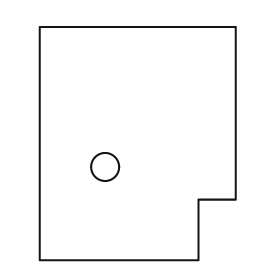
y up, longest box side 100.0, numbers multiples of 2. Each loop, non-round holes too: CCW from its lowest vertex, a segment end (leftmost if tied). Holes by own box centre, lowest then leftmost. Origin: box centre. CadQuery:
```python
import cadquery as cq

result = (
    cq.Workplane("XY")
    .moveTo(-42.0, -50.0)
    .lineTo(26.0, -50.0)
    .lineTo(26.0, -24.0)
    .lineTo(42.0, -24.0)
    .lineTo(42.0, 50.0)
    .lineTo(-42.0, 50.0)
    .close()
    .moveTo(-14.0, -10.0)
    .circle(6.0)
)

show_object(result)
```